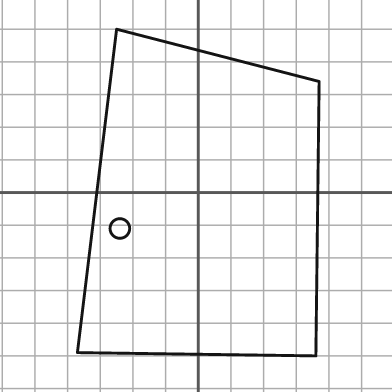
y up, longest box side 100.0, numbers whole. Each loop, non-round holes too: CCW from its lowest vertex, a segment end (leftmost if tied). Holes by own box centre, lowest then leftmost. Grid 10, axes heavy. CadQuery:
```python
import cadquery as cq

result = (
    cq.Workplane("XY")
    .moveTo(36.0, -50.0)
    .lineTo(37.0, 34.0)
    .lineTo(-25.0, 50.0)
    .lineTo(-37.0, -49.0)
    .close()
    .moveTo(-24.0, -11.0)
    .circle(3.0)
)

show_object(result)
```